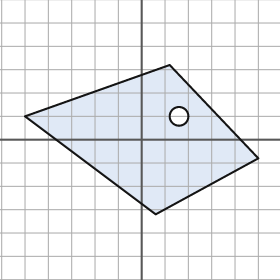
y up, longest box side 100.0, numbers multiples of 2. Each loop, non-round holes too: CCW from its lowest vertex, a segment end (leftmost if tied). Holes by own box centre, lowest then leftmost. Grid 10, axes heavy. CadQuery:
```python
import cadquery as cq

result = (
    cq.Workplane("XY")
    .moveTo(6.0, -32.0)
    .lineTo(50.0, -8.0)
    .lineTo(12.0, 32.0)
    .lineTo(-50.0, 10.0)
    .close()
    .moveTo(16.0, 10.0)
    .circle(4.0)
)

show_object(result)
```